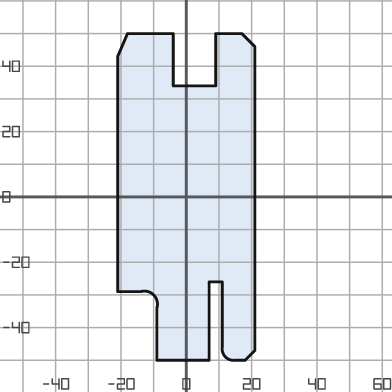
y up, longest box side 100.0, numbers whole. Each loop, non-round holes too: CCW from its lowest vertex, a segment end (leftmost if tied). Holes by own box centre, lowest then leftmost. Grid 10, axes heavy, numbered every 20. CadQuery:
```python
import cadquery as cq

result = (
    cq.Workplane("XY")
    .moveTo(-9.0, -50.0)
    .lineTo(7.0, -50.0)
    .lineTo(7.0, -26.0)
    .lineTo(11.0, -26.0)
    .lineTo(11.0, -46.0)
    .threePointArc((12.0, -49.0), (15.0, -50.0))
    .lineTo(18.0, -50.0)
    .lineTo(21.0, -47.0)
    .lineTo(21.0, 46.0)
    .lineTo(17.0, 50.0)
    .lineTo(9.0, 50.0)
    .lineTo(9.0, 34.0)
    .lineTo(-4.0, 34.0)
    .lineTo(-4.0, 50.0)
    .lineTo(-18.0, 50.0)
    .lineTo(-21.0, 43.0)
    .lineTo(-21.0, -29.0)
    .lineTo(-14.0, -29.0)
    .threePointArc((-10.0, -30.0), (-9.0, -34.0))
    .close()
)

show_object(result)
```